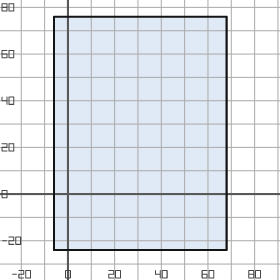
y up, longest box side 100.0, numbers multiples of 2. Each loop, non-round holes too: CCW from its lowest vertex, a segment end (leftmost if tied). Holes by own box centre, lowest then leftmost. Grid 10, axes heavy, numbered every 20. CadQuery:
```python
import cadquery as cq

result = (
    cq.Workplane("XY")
    .moveTo(-6.0, -24.0)
    .lineTo(68.0, -24.0)
    .lineTo(68.0, 76.0)
    .lineTo(-6.0, 76.0)
    .close()
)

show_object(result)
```